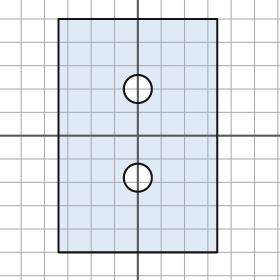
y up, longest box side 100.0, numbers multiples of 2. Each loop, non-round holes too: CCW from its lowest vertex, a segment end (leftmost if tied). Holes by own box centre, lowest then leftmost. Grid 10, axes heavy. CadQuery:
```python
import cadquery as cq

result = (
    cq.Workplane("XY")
    .moveTo(-34.0, -50.0)
    .lineTo(34.0, -50.0)
    .lineTo(34.0, 50.0)
    .lineTo(-34.0, 50.0)
    .close()
    .moveTo(0.0, -18.0)
    .circle(6.0)
    .moveTo(0.0, 20.0)
    .circle(6.0)
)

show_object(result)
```